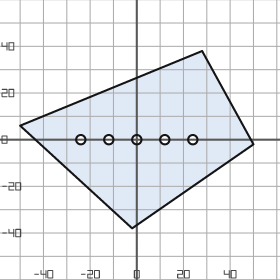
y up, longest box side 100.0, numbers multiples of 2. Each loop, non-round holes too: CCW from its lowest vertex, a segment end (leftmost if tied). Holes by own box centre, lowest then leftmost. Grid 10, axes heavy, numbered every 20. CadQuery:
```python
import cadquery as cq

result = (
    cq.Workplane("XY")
    .moveTo(-2.0, -38.0)
    .lineTo(50.0, -2.0)
    .lineTo(28.0, 38.0)
    .lineTo(-50.0, 6.0)
    .close()
    .moveTo(-24.0, 0.0)
    .circle(2.0)
    .moveTo(-12.0, 0.0)
    .circle(2.0)
    .moveTo(0.0, 0.0)
    .circle(2.0)
    .moveTo(12.0, 0.0)
    .circle(2.0)
    .moveTo(24.0, 0.0)
    .circle(2.0)
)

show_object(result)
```